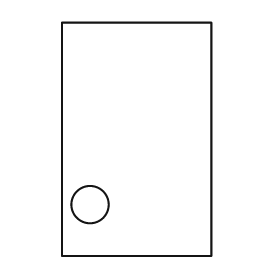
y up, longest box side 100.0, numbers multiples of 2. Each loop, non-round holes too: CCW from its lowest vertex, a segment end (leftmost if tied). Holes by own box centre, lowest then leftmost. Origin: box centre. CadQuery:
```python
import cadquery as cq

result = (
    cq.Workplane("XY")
    .moveTo(-32.0, -50.0)
    .lineTo(32.0, -50.0)
    .lineTo(32.0, 50.0)
    .lineTo(-32.0, 50.0)
    .close()
    .moveTo(-20.0, -28.0)
    .circle(8.0)
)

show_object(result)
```